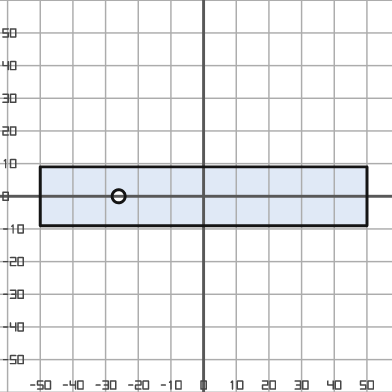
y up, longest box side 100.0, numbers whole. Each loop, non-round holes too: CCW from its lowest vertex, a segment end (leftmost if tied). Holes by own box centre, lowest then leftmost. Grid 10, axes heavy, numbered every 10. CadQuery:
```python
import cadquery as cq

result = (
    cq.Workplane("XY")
    .moveTo(-50.0, -9.0)
    .lineTo(50.0, -9.0)
    .lineTo(50.0, 9.0)
    .lineTo(-50.0, 9.0)
    .close()
    .moveTo(-26.0, 0.0)
    .circle(2.0)
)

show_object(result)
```